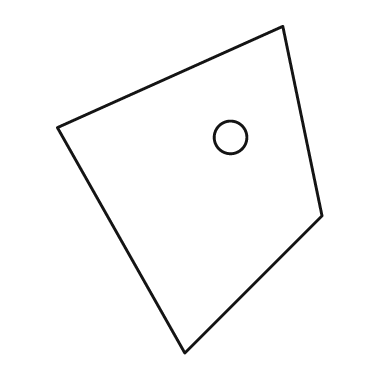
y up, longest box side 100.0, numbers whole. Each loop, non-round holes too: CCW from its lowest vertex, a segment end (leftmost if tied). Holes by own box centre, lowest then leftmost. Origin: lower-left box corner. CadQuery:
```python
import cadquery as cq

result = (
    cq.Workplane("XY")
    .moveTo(39.0, 0.0)
    .lineTo(81.0, 42.0)
    .lineTo(69.0, 100.0)
    .lineTo(0.0, 69.0)
    .close()
    .moveTo(53.0, 66.0)
    .circle(5.0)
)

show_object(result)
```